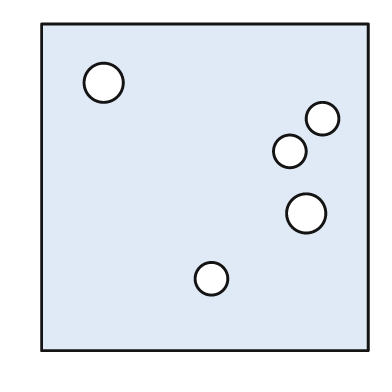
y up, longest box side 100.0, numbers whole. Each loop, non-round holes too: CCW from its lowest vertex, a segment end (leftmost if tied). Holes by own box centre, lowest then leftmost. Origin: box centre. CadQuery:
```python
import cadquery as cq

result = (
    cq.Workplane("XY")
    .moveTo(-50.0, -50.0)
    .lineTo(50.0, -50.0)
    .lineTo(50.0, 50.0)
    .lineTo(-50.0, 50.0)
    .close()
    .moveTo(2.0, -28.0)
    .circle(5.0)
    .moveTo(31.0, -8.0)
    .circle(6.0)
    .moveTo(26.0, 11.0)
    .circle(5.0)
    .moveTo(36.0, 21.0)
    .circle(5.0)
    .moveTo(-31.0, 32.0)
    .circle(6.0)
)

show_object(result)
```